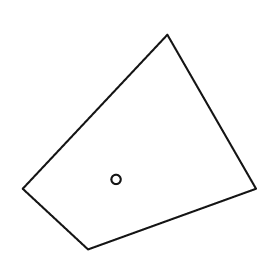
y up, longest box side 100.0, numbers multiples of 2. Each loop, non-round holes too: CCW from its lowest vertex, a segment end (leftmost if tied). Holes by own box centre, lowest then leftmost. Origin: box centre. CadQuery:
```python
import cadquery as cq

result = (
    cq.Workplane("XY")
    .moveTo(-22.0, -46.0)
    .lineTo(50.0, -20.0)
    .lineTo(12.0, 46.0)
    .lineTo(-50.0, -20.0)
    .close()
    .moveTo(-10.0, -16.0)
    .circle(2.0)
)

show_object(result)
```